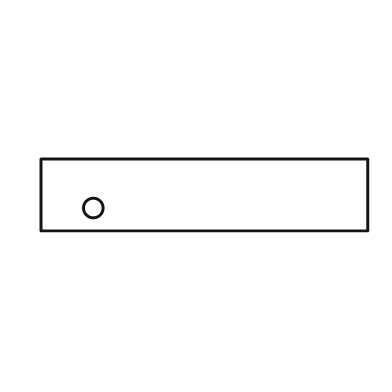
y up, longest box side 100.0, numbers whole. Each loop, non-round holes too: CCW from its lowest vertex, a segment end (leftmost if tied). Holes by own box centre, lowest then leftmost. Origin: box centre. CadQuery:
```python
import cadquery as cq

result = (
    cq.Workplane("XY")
    .moveTo(-50.0, -11.0)
    .lineTo(50.0, -11.0)
    .lineTo(50.0, 11.0)
    .lineTo(-50.0, 11.0)
    .close()
    .moveTo(-34.0, -4.0)
    .circle(3.0)
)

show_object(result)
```